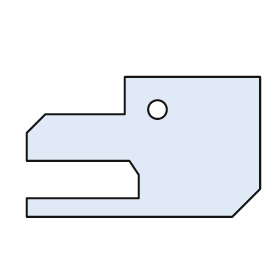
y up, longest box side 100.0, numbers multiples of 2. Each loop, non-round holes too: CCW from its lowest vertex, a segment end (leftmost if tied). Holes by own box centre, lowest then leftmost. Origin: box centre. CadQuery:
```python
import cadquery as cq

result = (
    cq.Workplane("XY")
    .moveTo(-50.0, -30.0)
    .lineTo(38.0, -30.0)
    .lineTo(50.0, -18.0)
    .lineTo(50.0, 30.0)
    .lineTo(-8.0, 30.0)
    .lineTo(-8.0, 14.0)
    .lineTo(-42.0, 14.0)
    .lineTo(-50.0, 6.0)
    .lineTo(-50.0, -6.0)
    .lineTo(-6.0, -6.0)
    .lineTo(-2.0, -12.0)
    .lineTo(-2.0, -22.0)
    .lineTo(-50.0, -22.0)
    .close()
    .moveTo(6.0, 16.0)
    .circle(4.0)
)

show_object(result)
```